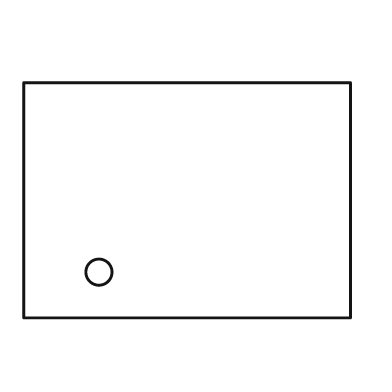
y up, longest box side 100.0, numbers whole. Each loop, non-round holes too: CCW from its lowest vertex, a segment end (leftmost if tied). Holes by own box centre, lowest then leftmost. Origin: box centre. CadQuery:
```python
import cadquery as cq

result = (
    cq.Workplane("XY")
    .moveTo(-50.0, -36.0)
    .lineTo(50.0, -36.0)
    .lineTo(50.0, 36.0)
    .lineTo(-50.0, 36.0)
    .close()
    .moveTo(-27.0, -22.0)
    .circle(4.0)
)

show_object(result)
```